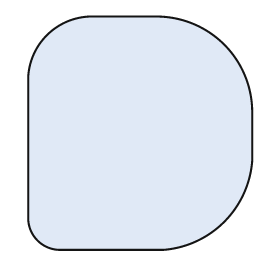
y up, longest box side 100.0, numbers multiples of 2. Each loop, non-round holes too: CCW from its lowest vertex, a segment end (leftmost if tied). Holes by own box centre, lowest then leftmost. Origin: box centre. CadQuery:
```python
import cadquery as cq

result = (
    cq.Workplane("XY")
    .moveTo(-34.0, -50.0)
    .lineTo(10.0, -50.0)
    .threePointArc((36.0, -38.0), (48.0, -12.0))
    .lineTo(48.0, 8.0)
    .threePointArc((36.0, 38.0), (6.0, 50.0))
    .lineTo(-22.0, 50.0)
    .threePointArc((-40.0, 42.0), (-48.0, 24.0))
    .lineTo(-48.0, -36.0)
    .threePointArc((-44.0, -46.0), (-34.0, -50.0))
    .close()
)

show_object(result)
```